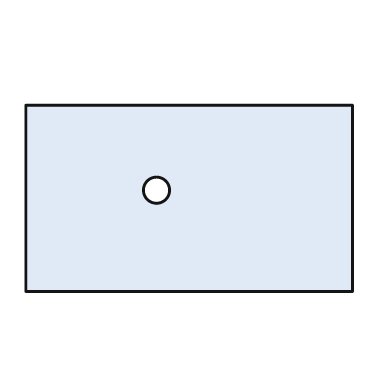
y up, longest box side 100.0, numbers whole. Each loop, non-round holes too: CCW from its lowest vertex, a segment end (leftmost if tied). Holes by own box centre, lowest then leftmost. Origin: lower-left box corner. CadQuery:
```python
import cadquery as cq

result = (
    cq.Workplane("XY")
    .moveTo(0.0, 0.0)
    .lineTo(100.0, 0.0)
    .lineTo(100.0, 57.0)
    .lineTo(0.0, 57.0)
    .close()
    .moveTo(40.0, 31.0)
    .circle(4.0)
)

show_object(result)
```